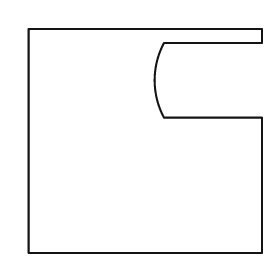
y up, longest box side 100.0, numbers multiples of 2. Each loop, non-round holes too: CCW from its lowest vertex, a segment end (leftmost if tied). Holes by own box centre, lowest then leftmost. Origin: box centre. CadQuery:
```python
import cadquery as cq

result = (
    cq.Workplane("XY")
    .moveTo(-50.0, -48.0)
    .lineTo(50.0, -48.0)
    .lineTo(50.0, 10.0)
    .lineTo(8.0, 10.0)
    .threePointArc((4.0, 26.0), (8.0, 42.0))
    .lineTo(50.0, 42.0)
    .lineTo(50.0, 48.0)
    .lineTo(-50.0, 48.0)
    .close()
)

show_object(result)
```